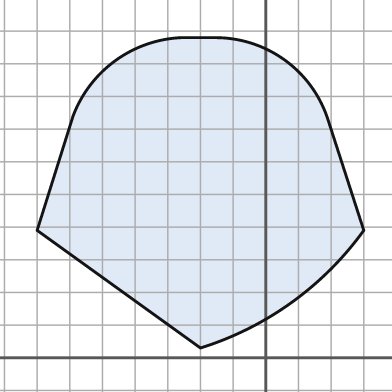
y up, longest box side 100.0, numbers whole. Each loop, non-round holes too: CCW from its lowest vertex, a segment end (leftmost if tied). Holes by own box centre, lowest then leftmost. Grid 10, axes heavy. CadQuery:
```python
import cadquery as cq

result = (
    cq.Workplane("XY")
    .moveTo(-20.0, 3.0)
    .threePointArc((8.0, 17.0), (30.0, 39.0))
    .lineTo(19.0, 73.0)
    .threePointArc((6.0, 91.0), (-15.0, 98.0))
    .lineTo(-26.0, 98.0)
    .threePointArc((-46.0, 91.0), (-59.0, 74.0))
    .lineTo(-70.0, 39.0)
    .close()
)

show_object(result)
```